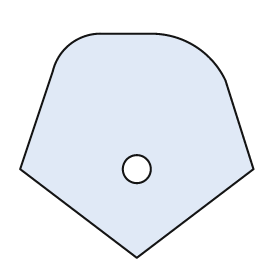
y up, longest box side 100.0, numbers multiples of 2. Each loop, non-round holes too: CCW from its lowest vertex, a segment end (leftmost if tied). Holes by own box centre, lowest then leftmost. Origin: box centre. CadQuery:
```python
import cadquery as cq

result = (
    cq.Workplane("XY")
    .moveTo(0.0, -48.0)
    .lineTo(50.0, -10.0)
    .lineTo(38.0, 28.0)
    .threePointArc((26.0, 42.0), (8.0, 48.0))
    .lineTo(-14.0, 48.0)
    .threePointArc((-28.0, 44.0), (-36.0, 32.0))
    .lineTo(-50.0, -10.0)
    .close()
    .moveTo(0.0, -10.0)
    .circle(6.0)
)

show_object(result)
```